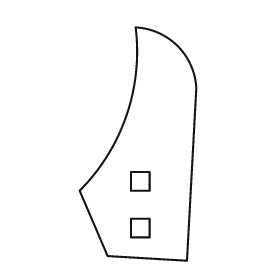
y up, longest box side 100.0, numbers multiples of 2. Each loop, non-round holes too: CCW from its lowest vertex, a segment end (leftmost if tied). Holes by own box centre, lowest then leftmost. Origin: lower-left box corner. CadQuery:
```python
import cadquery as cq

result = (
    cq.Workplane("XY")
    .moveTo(46.0, 0.0)
    .lineTo(50.0, 74.0)
    .threePointArc((42.0, 92.0), (24.0, 100.0))
    .threePointArc((20.0, 62.0), (0.0, 30.0))
    .lineTo(12.0, 2.0)
    .close()
    .moveTo(22.0, 10.0)
    .lineTo(30.0, 10.0)
    .lineTo(30.0, 18.0)
    .lineTo(22.0, 18.0)
    .close()
    .moveTo(22.0, 30.0)
    .lineTo(30.0, 30.0)
    .lineTo(30.0, 38.0)
    .lineTo(22.0, 38.0)
    .close()
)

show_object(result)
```